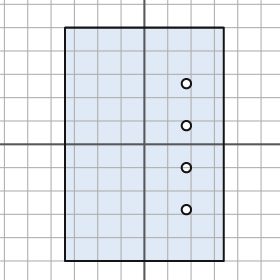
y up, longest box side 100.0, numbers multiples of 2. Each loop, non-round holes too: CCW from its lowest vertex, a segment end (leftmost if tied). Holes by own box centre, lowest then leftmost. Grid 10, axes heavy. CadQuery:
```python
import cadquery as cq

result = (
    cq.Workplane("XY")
    .moveTo(-34.0, -50.0)
    .lineTo(34.0, -50.0)
    .lineTo(34.0, 50.0)
    .lineTo(-34.0, 50.0)
    .close()
    .moveTo(18.0, -28.0)
    .circle(2.0)
    .moveTo(18.0, -10.0)
    .circle(2.0)
    .moveTo(18.0, 8.0)
    .circle(2.0)
    .moveTo(18.0, 26.0)
    .circle(2.0)
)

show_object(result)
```